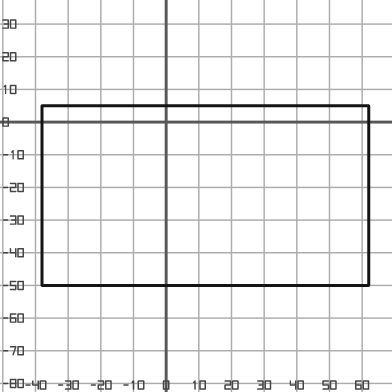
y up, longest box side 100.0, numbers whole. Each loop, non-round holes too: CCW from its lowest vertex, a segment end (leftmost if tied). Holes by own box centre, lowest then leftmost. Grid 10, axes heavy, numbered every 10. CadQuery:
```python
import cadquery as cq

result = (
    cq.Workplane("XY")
    .moveTo(-38.0, -50.0)
    .lineTo(62.0, -50.0)
    .lineTo(62.0, 5.0)
    .lineTo(-38.0, 5.0)
    .close()
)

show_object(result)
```